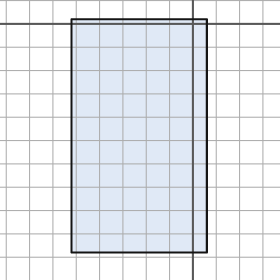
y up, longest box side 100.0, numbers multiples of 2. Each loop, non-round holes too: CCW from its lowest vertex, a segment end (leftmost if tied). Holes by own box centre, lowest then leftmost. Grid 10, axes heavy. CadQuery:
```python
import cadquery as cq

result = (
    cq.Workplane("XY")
    .moveTo(-52.0, -98.0)
    .lineTo(6.0, -98.0)
    .lineTo(6.0, 2.0)
    .lineTo(-52.0, 2.0)
    .close()
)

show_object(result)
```